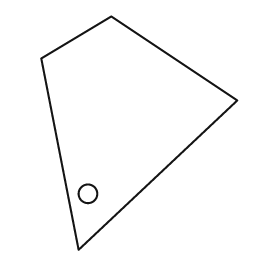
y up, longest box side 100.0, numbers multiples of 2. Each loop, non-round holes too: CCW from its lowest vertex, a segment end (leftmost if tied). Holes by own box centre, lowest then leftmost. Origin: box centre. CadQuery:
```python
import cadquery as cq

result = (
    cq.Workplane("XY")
    .moveTo(-26.0, -50.0)
    .lineTo(42.0, 14.0)
    .lineTo(-12.0, 50.0)
    .lineTo(-42.0, 32.0)
    .close()
    .moveTo(-22.0, -26.0)
    .circle(4.0)
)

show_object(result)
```